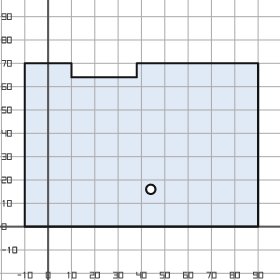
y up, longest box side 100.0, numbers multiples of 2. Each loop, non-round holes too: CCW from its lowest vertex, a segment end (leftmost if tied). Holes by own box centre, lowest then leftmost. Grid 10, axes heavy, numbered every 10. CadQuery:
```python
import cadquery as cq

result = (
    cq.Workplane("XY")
    .moveTo(-10.0, 0.0)
    .lineTo(90.0, 0.0)
    .lineTo(90.0, 70.0)
    .lineTo(38.0, 70.0)
    .lineTo(38.0, 64.0)
    .lineTo(10.0, 64.0)
    .lineTo(10.0, 70.0)
    .lineTo(-10.0, 70.0)
    .close()
    .moveTo(44.0, 16.0)
    .circle(2.0)
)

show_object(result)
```